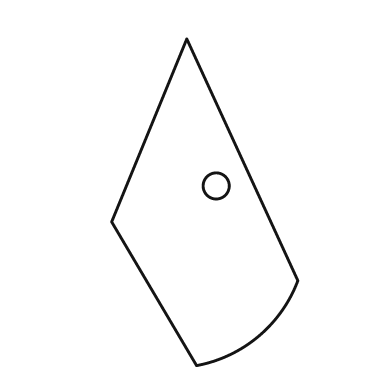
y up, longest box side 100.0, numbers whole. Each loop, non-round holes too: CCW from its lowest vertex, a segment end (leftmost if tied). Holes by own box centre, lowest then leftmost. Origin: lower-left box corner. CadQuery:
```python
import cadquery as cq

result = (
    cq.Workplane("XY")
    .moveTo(26.0, 0.0)
    .threePointArc((45.0, 9.0), (57.0, 26.0))
    .lineTo(23.0, 100.0)
    .lineTo(0.0, 44.0)
    .close()
    .moveTo(32.0, 55.0)
    .circle(4.0)
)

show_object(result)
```